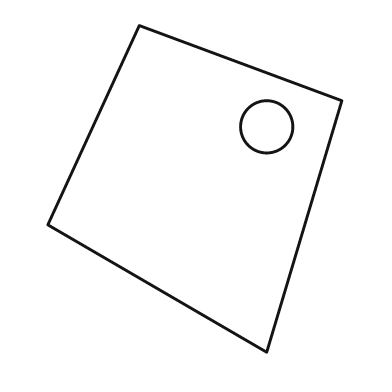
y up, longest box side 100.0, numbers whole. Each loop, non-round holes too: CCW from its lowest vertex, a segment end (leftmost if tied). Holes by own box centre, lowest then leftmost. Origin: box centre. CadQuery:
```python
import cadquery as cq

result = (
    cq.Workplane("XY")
    .moveTo(22.0, -50.0)
    .lineTo(45.0, 27.0)
    .lineTo(-17.0, 50.0)
    .lineTo(-45.0, -11.0)
    .close()
    .moveTo(22.0, 19.0)
    .circle(8.0)
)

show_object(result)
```